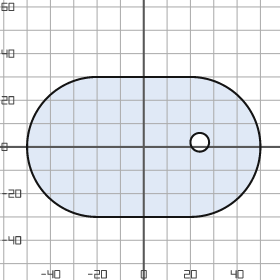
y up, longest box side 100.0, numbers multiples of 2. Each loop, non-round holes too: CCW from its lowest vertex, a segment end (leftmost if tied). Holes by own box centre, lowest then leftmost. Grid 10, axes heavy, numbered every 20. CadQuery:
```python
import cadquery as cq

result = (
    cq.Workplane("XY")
    .moveTo(-20.0, -30.0)
    .lineTo(20.0, -30.0)
    .threePointArc((50.0, 0.0), (20.0, 30.0))
    .lineTo(-20.0, 30.0)
    .threePointArc((-50.0, 0.0), (-20.0, -30.0))
    .close()
    .moveTo(24.0, 2.0)
    .circle(4.0)
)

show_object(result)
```